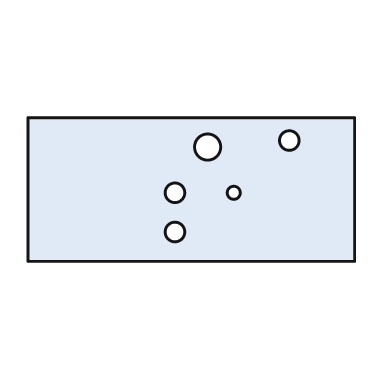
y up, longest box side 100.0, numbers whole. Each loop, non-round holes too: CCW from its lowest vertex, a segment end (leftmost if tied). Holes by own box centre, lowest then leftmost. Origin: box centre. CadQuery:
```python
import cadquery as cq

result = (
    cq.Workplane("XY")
    .moveTo(-50.0, -22.0)
    .lineTo(50.0, -22.0)
    .lineTo(50.0, 22.0)
    .lineTo(-50.0, 22.0)
    .close()
    .moveTo(-5.0, -13.0)
    .circle(3.0)
    .moveTo(-5.0, -1.0)
    .circle(3.0)
    .moveTo(13.0, -1.0)
    .circle(2.0)
    .moveTo(5.0, 13.0)
    .circle(4.0)
    .moveTo(30.0, 15.0)
    .circle(3.0)
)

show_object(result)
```